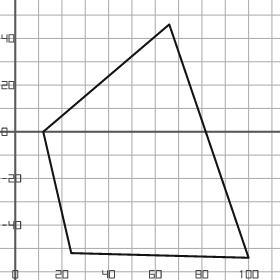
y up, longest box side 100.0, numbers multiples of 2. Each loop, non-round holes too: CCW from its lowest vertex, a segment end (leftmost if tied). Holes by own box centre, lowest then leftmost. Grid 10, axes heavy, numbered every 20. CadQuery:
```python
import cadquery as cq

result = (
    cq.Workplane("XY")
    .moveTo(100.0, -54.0)
    .lineTo(66.0, 46.0)
    .lineTo(12.0, 0.0)
    .lineTo(24.0, -52.0)
    .close()
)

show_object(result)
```